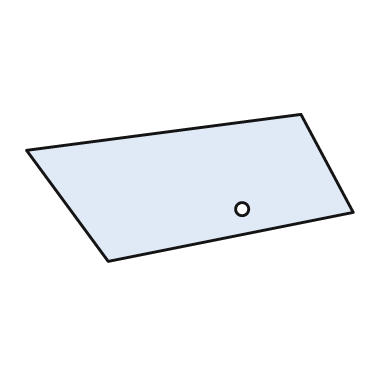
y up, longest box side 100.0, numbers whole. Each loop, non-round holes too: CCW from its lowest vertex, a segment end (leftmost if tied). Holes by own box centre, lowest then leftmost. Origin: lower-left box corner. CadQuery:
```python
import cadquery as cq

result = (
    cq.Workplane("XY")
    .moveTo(25.0, 0.0)
    .lineTo(100.0, 15.0)
    .lineTo(84.0, 45.0)
    .lineTo(0.0, 34.0)
    .close()
    .moveTo(66.0, 16.0)
    .circle(2.0)
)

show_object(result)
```